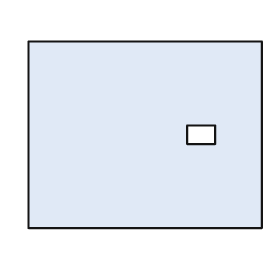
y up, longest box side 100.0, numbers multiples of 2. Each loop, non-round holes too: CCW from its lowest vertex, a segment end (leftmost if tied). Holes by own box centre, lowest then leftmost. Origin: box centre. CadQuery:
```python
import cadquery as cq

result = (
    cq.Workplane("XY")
    .moveTo(-50.0, -40.0)
    .lineTo(50.0, -40.0)
    .lineTo(50.0, 40.0)
    .lineTo(-50.0, 40.0)
    .close()
    .moveTo(18.0, -4.0)
    .lineTo(30.0, -4.0)
    .lineTo(30.0, 4.0)
    .lineTo(18.0, 4.0)
    .close()
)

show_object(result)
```